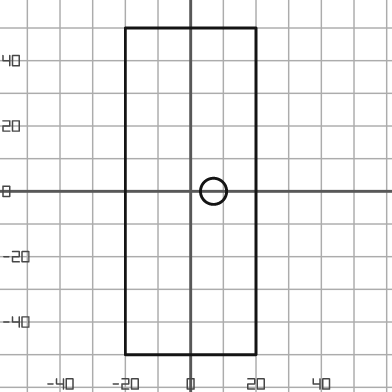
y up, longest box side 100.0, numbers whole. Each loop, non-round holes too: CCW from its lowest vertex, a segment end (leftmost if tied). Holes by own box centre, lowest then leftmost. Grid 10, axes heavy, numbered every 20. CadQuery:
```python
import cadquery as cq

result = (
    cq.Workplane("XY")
    .moveTo(-20.0, -50.0)
    .lineTo(20.0, -50.0)
    .lineTo(20.0, 50.0)
    .lineTo(-20.0, 50.0)
    .close()
    .moveTo(7.0, 0.0)
    .circle(4.0)
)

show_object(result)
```